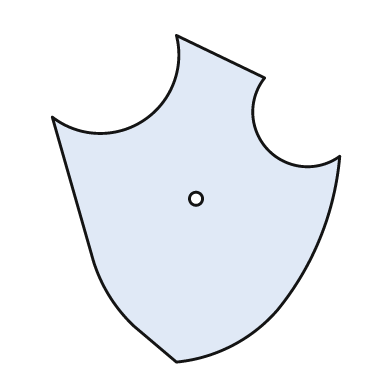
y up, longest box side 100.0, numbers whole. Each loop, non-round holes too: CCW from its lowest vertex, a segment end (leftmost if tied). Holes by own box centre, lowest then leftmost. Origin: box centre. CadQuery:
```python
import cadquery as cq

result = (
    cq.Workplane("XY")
    .moveTo(-6.0, -50.0)
    .threePointArc((11.0, -45.0), (25.0, -34.0))
    .threePointArc((38.0, -12.0), (44.0, 13.0))
    .threePointArc((22.0, 15.0), (21.0, 37.0))
    .lineTo(-6.0, 50.0)
    .threePointArc((-16.0, 24.0), (-44.0, 25.0))
    .lineTo(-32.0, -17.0)
    .threePointArc((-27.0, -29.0), (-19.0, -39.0))
    .close()
    .moveTo(0.0, 0.0)
    .circle(2.0)
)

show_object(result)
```